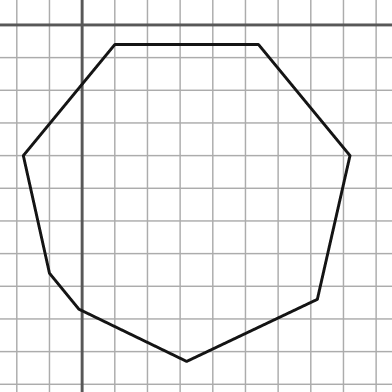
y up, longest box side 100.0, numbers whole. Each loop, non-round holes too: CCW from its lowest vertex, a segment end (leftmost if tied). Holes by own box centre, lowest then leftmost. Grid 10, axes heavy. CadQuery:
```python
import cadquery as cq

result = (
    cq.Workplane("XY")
    .moveTo(32.0, -103.0)
    .lineTo(72.0, -84.0)
    .lineTo(82.0, -40.0)
    .lineTo(54.0, -6.0)
    .lineTo(10.0, -6.0)
    .lineTo(-18.0, -40.0)
    .lineTo(-10.0, -76.0)
    .lineTo(-1.0, -87.0)
    .close()
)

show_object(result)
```